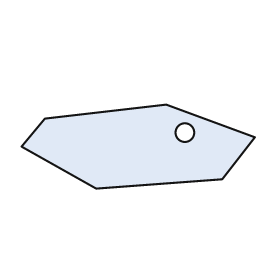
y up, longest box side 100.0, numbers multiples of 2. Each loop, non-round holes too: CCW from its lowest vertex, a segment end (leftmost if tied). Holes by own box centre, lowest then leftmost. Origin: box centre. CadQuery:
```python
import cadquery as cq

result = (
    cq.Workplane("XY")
    .moveTo(-18.0, -18.0)
    .lineTo(36.0, -14.0)
    .lineTo(50.0, 4.0)
    .lineTo(12.0, 18.0)
    .lineTo(-40.0, 12.0)
    .lineTo(-50.0, 0.0)
    .close()
    .moveTo(20.0, 6.0)
    .circle(4.0)
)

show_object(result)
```